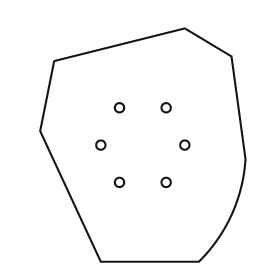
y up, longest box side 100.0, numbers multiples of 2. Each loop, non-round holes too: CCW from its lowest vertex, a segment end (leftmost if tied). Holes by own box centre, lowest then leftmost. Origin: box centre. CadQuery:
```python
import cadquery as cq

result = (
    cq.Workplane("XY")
    .moveTo(-18.0, -50.0)
    .lineTo(24.0, -50.0)
    .threePointArc((38.0, -30.0), (44.0, -6.0))
    .lineTo(38.0, 38.0)
    .lineTo(18.0, 50.0)
    .lineTo(-38.0, 36.0)
    .lineTo(-44.0, 6.0)
    .close()
    .moveTo(-10.0, -16.0)
    .circle(2.0)
    .moveTo(10.0, -16.0)
    .circle(2.0)
    .moveTo(-18.0, 0.0)
    .circle(2.0)
    .moveTo(18.0, 0.0)
    .circle(2.0)
    .moveTo(-10.0, 16.0)
    .circle(2.0)
    .moveTo(10.0, 16.0)
    .circle(2.0)
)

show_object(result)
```